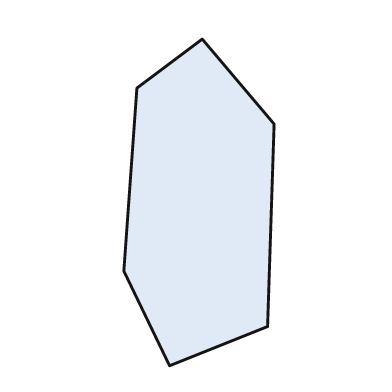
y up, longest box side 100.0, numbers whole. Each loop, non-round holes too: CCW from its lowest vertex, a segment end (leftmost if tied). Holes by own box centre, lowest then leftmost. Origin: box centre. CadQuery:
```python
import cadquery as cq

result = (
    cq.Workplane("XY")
    .moveTo(-9.0, -50.0)
    .lineTo(21.0, -38.0)
    .lineTo(23.0, 24.0)
    .lineTo(1.0, 50.0)
    .lineTo(-19.0, 35.0)
    .lineTo(-23.0, -21.0)
    .close()
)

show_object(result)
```